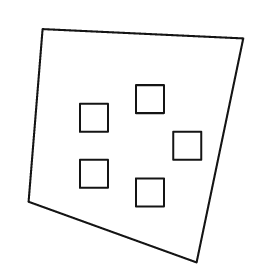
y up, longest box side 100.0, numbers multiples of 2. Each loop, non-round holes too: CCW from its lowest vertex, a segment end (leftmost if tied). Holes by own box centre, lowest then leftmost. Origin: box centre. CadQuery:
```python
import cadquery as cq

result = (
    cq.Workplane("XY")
    .moveTo(26.0, -50.0)
    .lineTo(46.0, 46.0)
    .lineTo(-40.0, 50.0)
    .lineTo(-46.0, -24.0)
    .close()
    .moveTo(0.0, -26.0)
    .lineTo(12.0, -26.0)
    .lineTo(12.0, -14.0)
    .lineTo(0.0, -14.0)
    .close()
    .moveTo(-24.0, -18.0)
    .lineTo(-12.0, -18.0)
    .lineTo(-12.0, -6.0)
    .lineTo(-24.0, -6.0)
    .close()
    .moveTo(16.0, -6.0)
    .lineTo(28.0, -6.0)
    .lineTo(28.0, 6.0)
    .lineTo(16.0, 6.0)
    .close()
    .moveTo(-24.0, 6.0)
    .lineTo(-12.0, 6.0)
    .lineTo(-12.0, 18.0)
    .lineTo(-24.0, 18.0)
    .close()
    .moveTo(0.0, 14.0)
    .lineTo(12.0, 14.0)
    .lineTo(12.0, 26.0)
    .lineTo(0.0, 26.0)
    .close()
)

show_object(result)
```